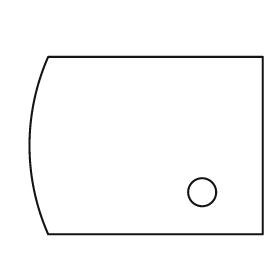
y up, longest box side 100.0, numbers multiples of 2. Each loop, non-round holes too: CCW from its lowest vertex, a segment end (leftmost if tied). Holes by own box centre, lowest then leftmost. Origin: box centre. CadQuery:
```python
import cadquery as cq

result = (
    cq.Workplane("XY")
    .moveTo(-42.0, -38.0)
    .lineTo(50.0, -38.0)
    .lineTo(50.0, 38.0)
    .lineTo(-42.0, 38.0)
    .threePointArc((-50.0, 0.0), (-42.0, -38.0))
    .close()
    .moveTo(24.0, -20.0)
    .circle(6.0)
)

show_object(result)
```